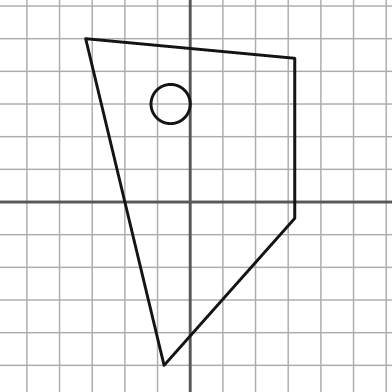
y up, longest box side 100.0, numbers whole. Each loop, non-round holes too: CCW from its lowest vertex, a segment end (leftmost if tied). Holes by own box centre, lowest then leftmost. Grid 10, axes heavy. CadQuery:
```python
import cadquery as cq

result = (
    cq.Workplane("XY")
    .moveTo(-8.0, -50.0)
    .lineTo(32.0, -5.0)
    .lineTo(32.0, 44.0)
    .lineTo(-32.0, 50.0)
    .close()
    .moveTo(-6.0, 30.0)
    .circle(6.0)
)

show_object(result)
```